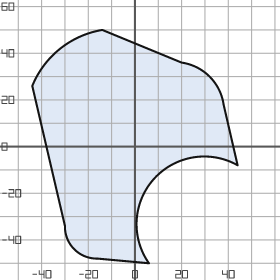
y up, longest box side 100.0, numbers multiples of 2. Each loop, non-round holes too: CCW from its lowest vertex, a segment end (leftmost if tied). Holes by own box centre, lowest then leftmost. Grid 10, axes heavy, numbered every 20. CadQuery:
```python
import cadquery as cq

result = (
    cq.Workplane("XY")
    .moveTo(6.0, -50.0)
    .threePointArc((8.0, -14.0), (44.0, -8.0))
    .lineTo(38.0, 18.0)
    .threePointArc((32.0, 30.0), (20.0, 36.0))
    .lineTo(-14.0, 50.0)
    .threePointArc((-32.0, 42.0), (-44.0, 26.0))
    .lineTo(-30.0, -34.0)
    .threePointArc((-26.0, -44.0), (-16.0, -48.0))
    .close()
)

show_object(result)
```